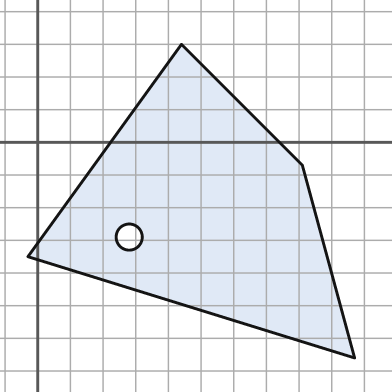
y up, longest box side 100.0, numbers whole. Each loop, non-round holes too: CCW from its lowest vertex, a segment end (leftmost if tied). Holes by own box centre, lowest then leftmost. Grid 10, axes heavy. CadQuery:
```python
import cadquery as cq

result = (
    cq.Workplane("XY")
    .moveTo(97.0, -66.0)
    .lineTo(81.0, -7.0)
    .lineTo(44.0, 30.0)
    .lineTo(-3.0, -35.0)
    .close()
    .moveTo(28.0, -29.0)
    .circle(4.0)
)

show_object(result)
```